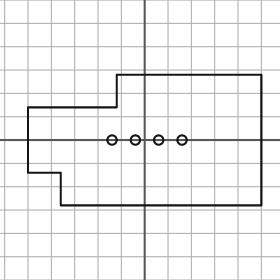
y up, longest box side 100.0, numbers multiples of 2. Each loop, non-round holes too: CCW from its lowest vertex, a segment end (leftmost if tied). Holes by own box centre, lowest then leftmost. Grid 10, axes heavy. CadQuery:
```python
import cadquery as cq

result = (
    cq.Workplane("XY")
    .moveTo(-36.0, -28.0)
    .lineTo(50.0, -28.0)
    .lineTo(50.0, 28.0)
    .lineTo(-12.0, 28.0)
    .lineTo(-12.0, 14.0)
    .lineTo(-50.0, 14.0)
    .lineTo(-50.0, -14.0)
    .lineTo(-36.0, -14.0)
    .close()
    .moveTo(-14.0, 0.0)
    .circle(2.0)
    .moveTo(-4.0, 0.0)
    .circle(2.0)
    .moveTo(6.0, 0.0)
    .circle(2.0)
    .moveTo(16.0, 0.0)
    .circle(2.0)
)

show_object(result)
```